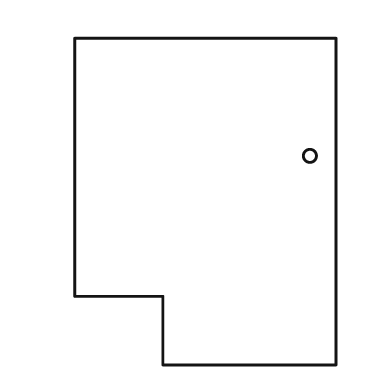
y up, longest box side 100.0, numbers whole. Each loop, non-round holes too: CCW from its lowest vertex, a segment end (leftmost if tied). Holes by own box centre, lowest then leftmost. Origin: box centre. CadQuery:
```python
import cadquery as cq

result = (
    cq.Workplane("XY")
    .moveTo(-13.0, -50.0)
    .lineTo(40.0, -50.0)
    .lineTo(40.0, 50.0)
    .lineTo(-40.0, 50.0)
    .lineTo(-40.0, -29.0)
    .lineTo(-13.0, -29.0)
    .close()
    .moveTo(32.0, 14.0)
    .circle(2.0)
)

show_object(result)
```